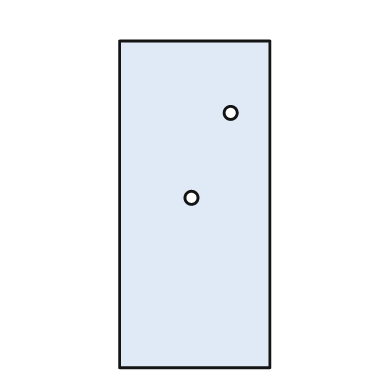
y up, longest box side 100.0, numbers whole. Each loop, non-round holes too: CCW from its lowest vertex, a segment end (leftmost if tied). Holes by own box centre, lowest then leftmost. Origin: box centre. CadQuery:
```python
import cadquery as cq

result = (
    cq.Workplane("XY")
    .moveTo(-23.0, -50.0)
    .lineTo(23.0, -50.0)
    .lineTo(23.0, 50.0)
    .lineTo(-23.0, 50.0)
    .close()
    .moveTo(-1.0, 2.0)
    .circle(2.0)
    .moveTo(11.0, 28.0)
    .circle(2.0)
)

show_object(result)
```